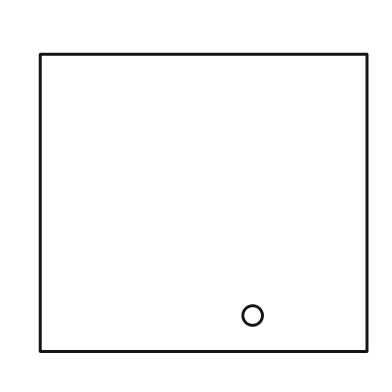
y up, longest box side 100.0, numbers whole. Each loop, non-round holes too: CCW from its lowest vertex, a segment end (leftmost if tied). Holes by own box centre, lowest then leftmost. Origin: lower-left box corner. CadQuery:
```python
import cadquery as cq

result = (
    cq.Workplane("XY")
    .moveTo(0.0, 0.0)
    .lineTo(100.0, 0.0)
    .lineTo(100.0, 91.0)
    .lineTo(0.0, 91.0)
    .close()
    .moveTo(65.0, 11.0)
    .circle(3.0)
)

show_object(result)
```